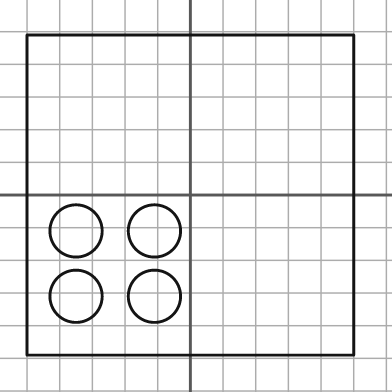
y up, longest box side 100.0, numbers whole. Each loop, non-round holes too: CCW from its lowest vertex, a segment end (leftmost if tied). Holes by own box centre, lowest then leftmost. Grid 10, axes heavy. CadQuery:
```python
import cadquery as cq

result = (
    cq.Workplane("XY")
    .moveTo(-50.0, -49.0)
    .lineTo(50.0, -49.0)
    .lineTo(50.0, 49.0)
    .lineTo(-50.0, 49.0)
    .close()
    .moveTo(-35.0, -31.0)
    .circle(8.0)
    .moveTo(-11.0, -31.0)
    .circle(8.0)
    .moveTo(-35.0, -11.0)
    .circle(8.0)
    .moveTo(-11.0, -11.0)
    .circle(8.0)
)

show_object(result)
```